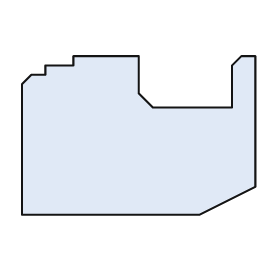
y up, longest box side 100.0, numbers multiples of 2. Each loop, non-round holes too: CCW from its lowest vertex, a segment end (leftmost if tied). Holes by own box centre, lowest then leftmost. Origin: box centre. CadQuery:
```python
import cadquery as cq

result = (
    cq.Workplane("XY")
    .moveTo(-50.0, -34.0)
    .lineTo(26.0, -34.0)
    .lineTo(50.0, -22.0)
    .lineTo(50.0, 34.0)
    .lineTo(44.0, 34.0)
    .lineTo(40.0, 30.0)
    .lineTo(40.0, 12.0)
    .lineTo(6.0, 12.0)
    .lineTo(0.0, 18.0)
    .lineTo(0.0, 34.0)
    .lineTo(-28.0, 34.0)
    .lineTo(-28.0, 30.0)
    .lineTo(-40.0, 30.0)
    .lineTo(-40.0, 26.0)
    .lineTo(-46.0, 26.0)
    .lineTo(-50.0, 22.0)
    .close()
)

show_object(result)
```